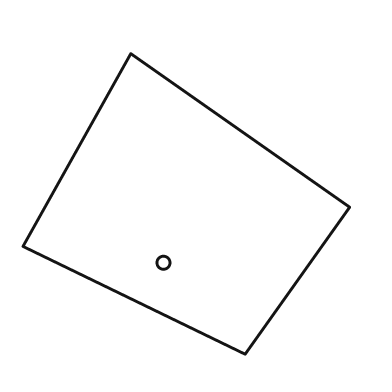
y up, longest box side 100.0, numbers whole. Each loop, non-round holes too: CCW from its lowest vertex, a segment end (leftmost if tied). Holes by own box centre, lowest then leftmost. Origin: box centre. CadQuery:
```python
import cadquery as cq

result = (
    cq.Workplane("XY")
    .moveTo(18.0, -46.0)
    .lineTo(50.0, -1.0)
    .lineTo(-17.0, 46.0)
    .lineTo(-50.0, -13.0)
    .close()
    .moveTo(-7.0, -18.0)
    .circle(2.0)
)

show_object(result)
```